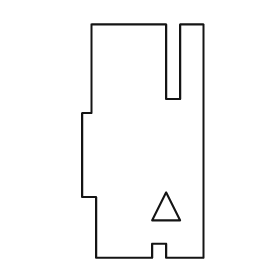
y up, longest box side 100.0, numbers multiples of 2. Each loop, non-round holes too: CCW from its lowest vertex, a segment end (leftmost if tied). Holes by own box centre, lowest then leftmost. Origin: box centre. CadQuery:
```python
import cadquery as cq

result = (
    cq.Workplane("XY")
    .moveTo(-20.0, -50.0)
    .lineTo(4.0, -50.0)
    .lineTo(4.0, -44.0)
    .lineTo(10.0, -44.0)
    .lineTo(10.0, -50.0)
    .lineTo(26.0, -50.0)
    .lineTo(26.0, 50.0)
    .lineTo(16.0, 50.0)
    .lineTo(16.0, 18.0)
    .lineTo(10.0, 18.0)
    .lineTo(10.0, 50.0)
    .lineTo(-22.0, 50.0)
    .lineTo(-22.0, 12.0)
    .lineTo(-26.0, 12.0)
    .lineTo(-26.0, -24.0)
    .lineTo(-20.0, -24.0)
    .close()
    .moveTo(4.0, -34.0)
    .lineTo(16.0, -34.0)
    .lineTo(10.0, -22.0)
    .close()
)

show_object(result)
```